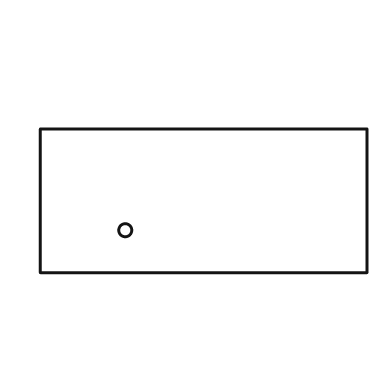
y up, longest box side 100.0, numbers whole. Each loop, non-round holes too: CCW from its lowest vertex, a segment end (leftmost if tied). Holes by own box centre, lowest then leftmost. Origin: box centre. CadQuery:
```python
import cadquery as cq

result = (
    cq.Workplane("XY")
    .moveTo(-50.0, -22.0)
    .lineTo(50.0, -22.0)
    .lineTo(50.0, 22.0)
    .lineTo(-50.0, 22.0)
    .close()
    .moveTo(-24.0, -9.0)
    .circle(2.0)
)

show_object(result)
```